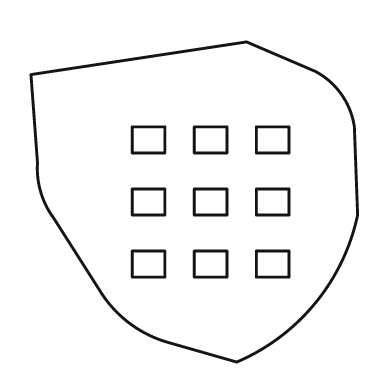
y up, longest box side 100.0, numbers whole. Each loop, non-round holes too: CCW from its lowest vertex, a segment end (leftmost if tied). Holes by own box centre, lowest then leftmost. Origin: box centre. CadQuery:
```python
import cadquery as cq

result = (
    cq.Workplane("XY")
    .moveTo(13.0, -49.0)
    .threePointArc((37.0, -31.0), (50.0, -4.0))
    .lineTo(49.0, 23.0)
    .threePointArc((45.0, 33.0), (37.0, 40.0))
    .lineTo(16.0, 49.0)
    .lineTo(-50.0, 39.0)
    .lineTo(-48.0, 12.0)
    .threePointArc((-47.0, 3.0), (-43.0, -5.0))
    .lineTo(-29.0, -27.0)
    .threePointArc((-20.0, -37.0), (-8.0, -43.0))
    .close()
    .moveTo(-19.0, -23.0)
    .lineTo(-9.0, -23.0)
    .lineTo(-9.0, -15.0)
    .lineTo(-19.0, -15.0)
    .close()
    .moveTo(0.0, -23.0)
    .lineTo(10.0, -23.0)
    .lineTo(10.0, -15.0)
    .lineTo(0.0, -15.0)
    .close()
    .moveTo(19.0, -23.0)
    .lineTo(29.0, -23.0)
    .lineTo(29.0, -15.0)
    .lineTo(19.0, -15.0)
    .close()
    .moveTo(-19.0, -4.0)
    .lineTo(-9.0, -4.0)
    .lineTo(-9.0, 4.0)
    .lineTo(-19.0, 4.0)
    .close()
    .moveTo(0.0, -4.0)
    .lineTo(10.0, -4.0)
    .lineTo(10.0, 4.0)
    .lineTo(0.0, 4.0)
    .close()
    .moveTo(19.0, -4.0)
    .lineTo(29.0, -4.0)
    .lineTo(29.0, 4.0)
    .lineTo(19.0, 4.0)
    .close()
    .moveTo(-19.0, 15.0)
    .lineTo(-9.0, 15.0)
    .lineTo(-9.0, 23.0)
    .lineTo(-19.0, 23.0)
    .close()
    .moveTo(0.0, 15.0)
    .lineTo(10.0, 15.0)
    .lineTo(10.0, 23.0)
    .lineTo(0.0, 23.0)
    .close()
    .moveTo(19.0, 15.0)
    .lineTo(29.0, 15.0)
    .lineTo(29.0, 23.0)
    .lineTo(19.0, 23.0)
    .close()
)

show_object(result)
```